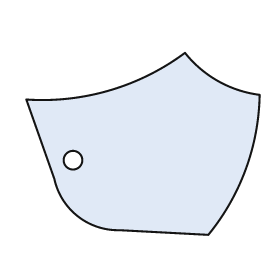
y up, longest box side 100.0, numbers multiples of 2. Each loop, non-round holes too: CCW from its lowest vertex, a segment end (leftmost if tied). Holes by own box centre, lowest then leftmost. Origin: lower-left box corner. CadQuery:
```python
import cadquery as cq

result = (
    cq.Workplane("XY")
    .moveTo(78.0, 0.0)
    .threePointArc((94.0, 28.0), (100.0, 60.0))
    .threePointArc((82.0, 66.0), (68.0, 78.0))
    .threePointArc((36.0, 62.0), (0.0, 58.0))
    .lineTo(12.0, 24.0)
    .threePointArc((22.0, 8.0), (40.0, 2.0))
    .close()
    .moveTo(20.0, 32.0)
    .circle(4.0)
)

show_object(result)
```